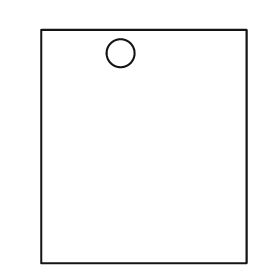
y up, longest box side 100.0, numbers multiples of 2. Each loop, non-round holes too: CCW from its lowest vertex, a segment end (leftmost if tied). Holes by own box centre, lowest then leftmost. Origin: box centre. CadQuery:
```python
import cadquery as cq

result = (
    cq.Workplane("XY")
    .moveTo(-44.0, -50.0)
    .lineTo(44.0, -50.0)
    .lineTo(44.0, 50.0)
    .lineTo(-44.0, 50.0)
    .close()
    .moveTo(-10.0, 40.0)
    .circle(6.0)
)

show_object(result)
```